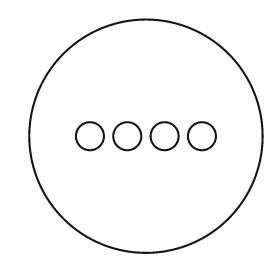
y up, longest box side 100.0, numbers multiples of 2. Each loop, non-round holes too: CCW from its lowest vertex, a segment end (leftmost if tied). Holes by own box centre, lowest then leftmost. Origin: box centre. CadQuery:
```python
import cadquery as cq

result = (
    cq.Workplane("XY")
    .moveTo(0.0, 0.0)
    .circle(50.0)
    .moveTo(-24.0, 0.0)
    .circle(6.0)
    .moveTo(-8.0, 0.0)
    .circle(6.0)
    .moveTo(8.0, 0.0)
    .circle(6.0)
    .moveTo(24.0, 0.0)
    .circle(6.0)
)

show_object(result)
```